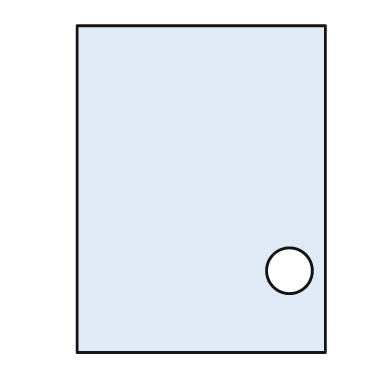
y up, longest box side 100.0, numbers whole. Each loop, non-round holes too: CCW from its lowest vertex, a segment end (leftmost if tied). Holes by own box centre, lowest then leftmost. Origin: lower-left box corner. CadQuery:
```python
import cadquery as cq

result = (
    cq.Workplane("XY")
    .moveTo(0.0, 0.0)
    .lineTo(76.0, 0.0)
    .lineTo(76.0, 100.0)
    .lineTo(0.0, 100.0)
    .close()
    .moveTo(65.0, 25.0)
    .circle(7.0)
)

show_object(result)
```